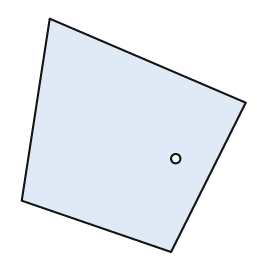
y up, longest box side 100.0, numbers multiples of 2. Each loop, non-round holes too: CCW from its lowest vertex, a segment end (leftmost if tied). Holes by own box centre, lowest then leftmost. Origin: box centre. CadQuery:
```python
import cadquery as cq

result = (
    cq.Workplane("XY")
    .moveTo(16.0, -50.0)
    .lineTo(48.0, 14.0)
    .lineTo(-36.0, 50.0)
    .lineTo(-48.0, -28.0)
    .close()
    .moveTo(18.0, -10.0)
    .circle(2.0)
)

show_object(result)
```